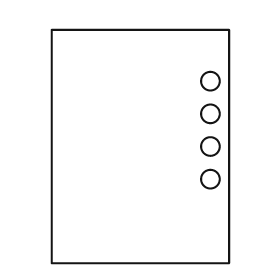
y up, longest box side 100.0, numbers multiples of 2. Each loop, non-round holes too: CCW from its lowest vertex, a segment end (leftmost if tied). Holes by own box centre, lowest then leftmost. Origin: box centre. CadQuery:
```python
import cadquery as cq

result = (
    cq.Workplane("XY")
    .moveTo(-38.0, -50.0)
    .lineTo(38.0, -50.0)
    .lineTo(38.0, 50.0)
    .lineTo(-38.0, 50.0)
    .close()
    .moveTo(30.0, -14.0)
    .circle(4.0)
    .moveTo(30.0, 0.0)
    .circle(4.0)
    .moveTo(30.0, 14.0)
    .circle(4.0)
    .moveTo(30.0, 28.0)
    .circle(4.0)
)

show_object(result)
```